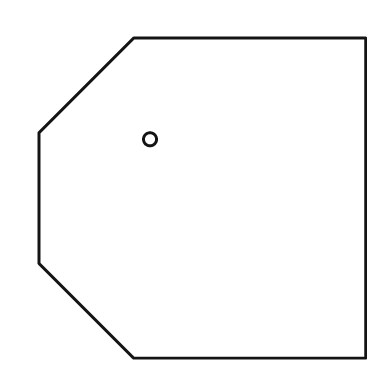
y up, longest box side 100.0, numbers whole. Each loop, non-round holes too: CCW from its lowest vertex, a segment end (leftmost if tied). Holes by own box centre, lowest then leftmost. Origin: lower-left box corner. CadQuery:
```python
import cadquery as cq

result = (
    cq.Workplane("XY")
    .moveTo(29.0, 0.0)
    .lineTo(100.0, 0.0)
    .lineTo(100.0, 98.0)
    .lineTo(29.0, 98.0)
    .lineTo(0.0, 69.0)
    .lineTo(0.0, 29.0)
    .close()
    .moveTo(34.0, 67.0)
    .circle(2.0)
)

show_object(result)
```